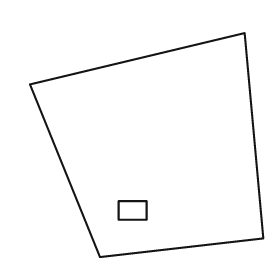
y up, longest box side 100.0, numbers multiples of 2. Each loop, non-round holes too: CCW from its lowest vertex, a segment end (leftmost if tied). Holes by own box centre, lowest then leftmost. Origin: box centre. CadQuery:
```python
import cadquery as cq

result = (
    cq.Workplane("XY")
    .moveTo(-20.0, -48.0)
    .lineTo(50.0, -40.0)
    .lineTo(42.0, 48.0)
    .lineTo(-50.0, 26.0)
    .close()
    .moveTo(-12.0, -32.0)
    .lineTo(0.0, -32.0)
    .lineTo(0.0, -24.0)
    .lineTo(-12.0, -24.0)
    .close()
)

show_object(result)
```